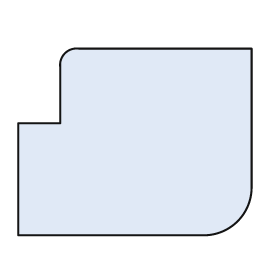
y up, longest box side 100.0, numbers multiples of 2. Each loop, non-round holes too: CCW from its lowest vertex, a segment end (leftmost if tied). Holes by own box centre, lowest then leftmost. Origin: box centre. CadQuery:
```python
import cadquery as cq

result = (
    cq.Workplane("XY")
    .moveTo(-50.0, -40.0)
    .lineTo(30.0, -40.0)
    .threePointArc((44.0, -34.0), (50.0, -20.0))
    .lineTo(50.0, 40.0)
    .lineTo(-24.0, 40.0)
    .threePointArc((-30.0, 38.0), (-32.0, 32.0))
    .lineTo(-32.0, 8.0)
    .lineTo(-50.0, 8.0)
    .close()
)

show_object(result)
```